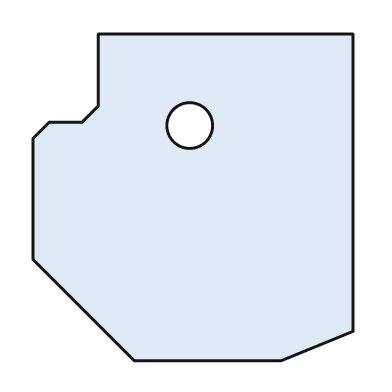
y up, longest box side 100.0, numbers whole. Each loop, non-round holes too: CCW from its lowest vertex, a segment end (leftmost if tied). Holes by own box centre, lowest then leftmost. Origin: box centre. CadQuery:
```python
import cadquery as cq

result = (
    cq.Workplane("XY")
    .moveTo(-18.0, -50.0)
    .lineTo(27.0, -50.0)
    .lineTo(49.0, -41.0)
    .lineTo(49.0, 50.0)
    .lineTo(-29.0, 50.0)
    .lineTo(-29.0, 28.0)
    .lineTo(-34.0, 23.0)
    .lineTo(-44.0, 23.0)
    .lineTo(-49.0, 18.0)
    .lineTo(-49.0, -19.0)
    .close()
    .moveTo(-1.0, 22.0)
    .circle(7.0)
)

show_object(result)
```